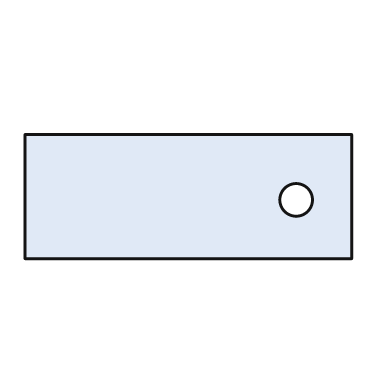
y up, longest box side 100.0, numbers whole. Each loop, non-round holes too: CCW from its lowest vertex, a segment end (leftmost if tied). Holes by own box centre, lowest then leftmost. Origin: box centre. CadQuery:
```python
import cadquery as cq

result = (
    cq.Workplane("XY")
    .moveTo(-50.0, -19.0)
    .lineTo(50.0, -19.0)
    .lineTo(50.0, 19.0)
    .lineTo(-50.0, 19.0)
    .close()
    .moveTo(33.0, -1.0)
    .circle(5.0)
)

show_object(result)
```